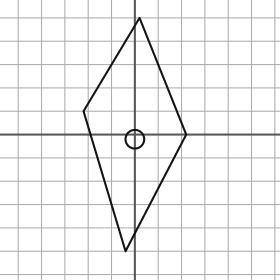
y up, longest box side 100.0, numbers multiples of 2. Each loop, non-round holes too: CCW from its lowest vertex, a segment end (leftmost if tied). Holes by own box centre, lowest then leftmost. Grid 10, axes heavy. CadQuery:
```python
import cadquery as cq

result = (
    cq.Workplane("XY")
    .moveTo(-4.0, -50.0)
    .lineTo(22.0, 0.0)
    .lineTo(2.0, 50.0)
    .lineTo(-22.0, 10.0)
    .close()
    .moveTo(0.0, -2.0)
    .circle(4.0)
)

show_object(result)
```